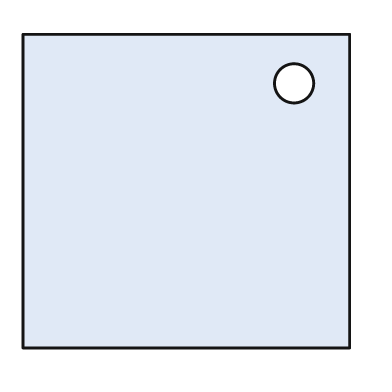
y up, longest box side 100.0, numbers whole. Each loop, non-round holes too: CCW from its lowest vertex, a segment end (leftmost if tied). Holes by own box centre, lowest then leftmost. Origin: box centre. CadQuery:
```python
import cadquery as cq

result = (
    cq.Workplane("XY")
    .moveTo(-50.0, -48.0)
    .lineTo(50.0, -48.0)
    .lineTo(50.0, 48.0)
    .lineTo(-50.0, 48.0)
    .close()
    .moveTo(33.0, 33.0)
    .circle(6.0)
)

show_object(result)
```